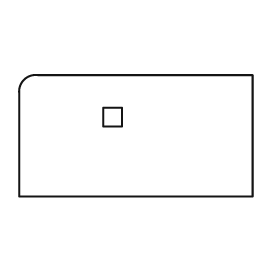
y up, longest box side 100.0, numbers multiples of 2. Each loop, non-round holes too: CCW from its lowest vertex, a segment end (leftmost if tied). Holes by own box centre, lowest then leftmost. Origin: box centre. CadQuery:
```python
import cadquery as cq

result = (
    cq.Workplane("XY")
    .moveTo(-50.0, -26.0)
    .lineTo(50.0, -26.0)
    .lineTo(50.0, 26.0)
    .lineTo(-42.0, 26.0)
    .threePointArc((-48.0, 24.0), (-50.0, 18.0))
    .close()
    .moveTo(-14.0, 4.0)
    .lineTo(-6.0, 4.0)
    .lineTo(-6.0, 12.0)
    .lineTo(-14.0, 12.0)
    .close()
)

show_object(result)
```